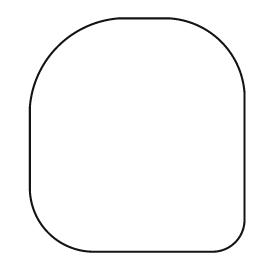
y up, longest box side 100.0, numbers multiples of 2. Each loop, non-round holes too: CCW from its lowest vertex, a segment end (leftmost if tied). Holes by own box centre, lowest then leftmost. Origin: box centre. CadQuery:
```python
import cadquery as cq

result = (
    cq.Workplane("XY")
    .moveTo(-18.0, -50.0)
    .lineTo(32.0, -50.0)
    .threePointArc((42.0, -46.0), (46.0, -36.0))
    .lineTo(46.0, 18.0)
    .threePointArc((36.0, 40.0), (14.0, 50.0))
    .lineTo(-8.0, 50.0)
    .threePointArc((-34.0, 38.0), (-46.0, 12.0))
    .lineTo(-46.0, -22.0)
    .threePointArc((-38.0, -42.0), (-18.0, -50.0))
    .close()
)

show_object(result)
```